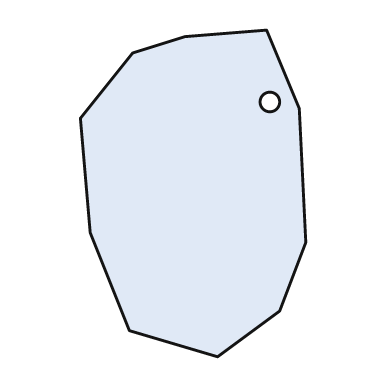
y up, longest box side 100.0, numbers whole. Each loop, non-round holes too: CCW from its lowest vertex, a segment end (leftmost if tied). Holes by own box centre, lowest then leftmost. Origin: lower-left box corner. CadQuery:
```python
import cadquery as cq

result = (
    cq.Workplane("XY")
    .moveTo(42.0, 0.0)
    .lineTo(61.0, 14.0)
    .lineTo(69.0, 35.0)
    .lineTo(67.0, 76.0)
    .lineTo(57.0, 100.0)
    .lineTo(32.0, 98.0)
    .lineTo(16.0, 93.0)
    .lineTo(0.0, 73.0)
    .lineTo(3.0, 38.0)
    .lineTo(15.0, 8.0)
    .close()
    .moveTo(58.0, 78.0)
    .circle(3.0)
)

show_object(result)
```